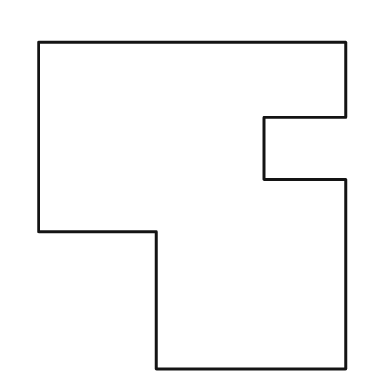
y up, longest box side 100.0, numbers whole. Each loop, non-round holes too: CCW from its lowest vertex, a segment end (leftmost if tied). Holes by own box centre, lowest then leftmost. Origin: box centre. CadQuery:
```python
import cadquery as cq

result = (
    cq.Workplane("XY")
    .moveTo(-11.0, -50.0)
    .lineTo(47.0, -50.0)
    .lineTo(47.0, 8.0)
    .lineTo(22.0, 8.0)
    .lineTo(22.0, 27.0)
    .lineTo(47.0, 27.0)
    .lineTo(47.0, 50.0)
    .lineTo(-47.0, 50.0)
    .lineTo(-47.0, -8.0)
    .lineTo(-11.0, -8.0)
    .close()
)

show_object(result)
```